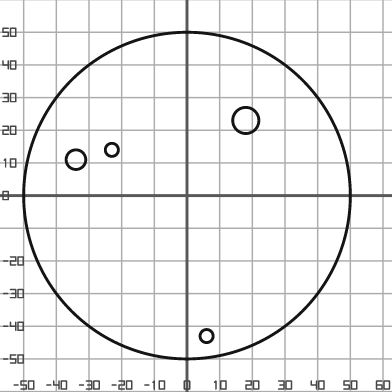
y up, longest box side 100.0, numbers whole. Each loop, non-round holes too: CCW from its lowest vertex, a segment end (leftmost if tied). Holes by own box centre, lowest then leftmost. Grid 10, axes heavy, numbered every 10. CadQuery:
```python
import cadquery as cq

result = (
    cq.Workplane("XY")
    .moveTo(0.0, 0.0)
    .circle(50.0)
    .moveTo(6.0, -43.0)
    .circle(2.0)
    .moveTo(-34.0, 11.0)
    .circle(3.0)
    .moveTo(-23.0, 14.0)
    .circle(2.0)
    .moveTo(18.0, 23.0)
    .circle(4.0)
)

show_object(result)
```